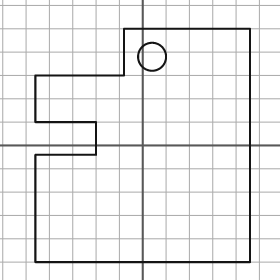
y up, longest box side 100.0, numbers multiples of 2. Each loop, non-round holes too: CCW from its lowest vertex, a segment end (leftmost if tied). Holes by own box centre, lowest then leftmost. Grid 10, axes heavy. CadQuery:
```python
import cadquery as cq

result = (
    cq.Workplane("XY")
    .moveTo(-46.0, -50.0)
    .lineTo(46.0, -50.0)
    .lineTo(46.0, 50.0)
    .lineTo(-8.0, 50.0)
    .lineTo(-8.0, 30.0)
    .lineTo(-46.0, 30.0)
    .lineTo(-46.0, 10.0)
    .lineTo(-20.0, 10.0)
    .lineTo(-20.0, -4.0)
    .lineTo(-46.0, -4.0)
    .close()
    .moveTo(4.0, 38.0)
    .circle(6.0)
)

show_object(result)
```